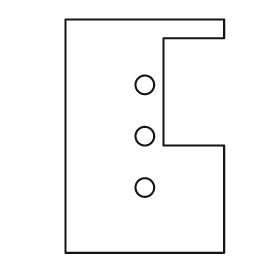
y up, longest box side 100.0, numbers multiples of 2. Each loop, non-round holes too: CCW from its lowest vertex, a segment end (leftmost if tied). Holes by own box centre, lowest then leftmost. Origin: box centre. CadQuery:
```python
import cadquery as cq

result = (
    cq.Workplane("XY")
    .moveTo(-34.0, -50.0)
    .lineTo(34.0, -50.0)
    .lineTo(34.0, -4.0)
    .lineTo(8.0, -4.0)
    .lineTo(8.0, 42.0)
    .lineTo(34.0, 42.0)
    .lineTo(34.0, 50.0)
    .lineTo(-34.0, 50.0)
    .close()
    .moveTo(0.0, -22.0)
    .circle(4.0)
    .moveTo(0.0, 0.0)
    .circle(4.0)
    .moveTo(0.0, 22.0)
    .circle(4.0)
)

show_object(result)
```